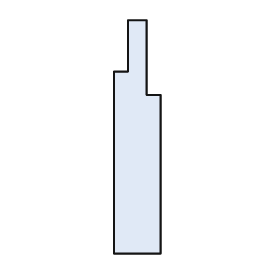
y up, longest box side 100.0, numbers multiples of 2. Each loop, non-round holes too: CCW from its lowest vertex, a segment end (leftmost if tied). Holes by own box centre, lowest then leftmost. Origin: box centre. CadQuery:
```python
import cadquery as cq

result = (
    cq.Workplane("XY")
    .moveTo(-10.0, -50.0)
    .lineTo(10.0, -50.0)
    .lineTo(10.0, 18.0)
    .lineTo(4.0, 18.0)
    .lineTo(4.0, 50.0)
    .lineTo(-4.0, 50.0)
    .lineTo(-4.0, 28.0)
    .lineTo(-10.0, 28.0)
    .close()
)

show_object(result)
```